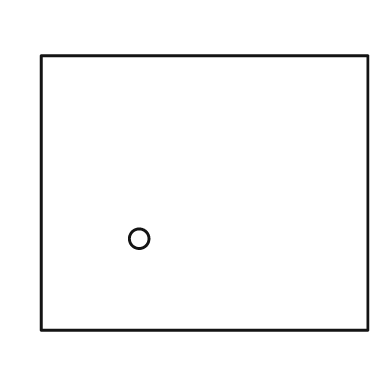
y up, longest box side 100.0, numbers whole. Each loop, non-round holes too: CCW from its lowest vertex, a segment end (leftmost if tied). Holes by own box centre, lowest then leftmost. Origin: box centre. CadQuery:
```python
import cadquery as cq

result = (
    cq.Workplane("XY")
    .moveTo(-50.0, -42.0)
    .lineTo(50.0, -42.0)
    .lineTo(50.0, 42.0)
    .lineTo(-50.0, 42.0)
    .close()
    .moveTo(-20.0, -14.0)
    .circle(3.0)
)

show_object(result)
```